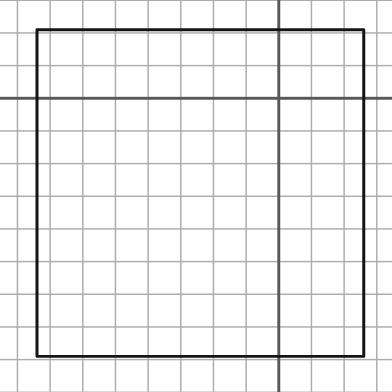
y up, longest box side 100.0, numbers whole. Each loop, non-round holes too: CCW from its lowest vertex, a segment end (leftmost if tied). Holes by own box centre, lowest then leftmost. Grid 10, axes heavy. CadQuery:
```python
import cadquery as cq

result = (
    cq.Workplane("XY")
    .moveTo(-74.0, -79.0)
    .lineTo(26.0, -79.0)
    .lineTo(26.0, 21.0)
    .lineTo(-74.0, 21.0)
    .close()
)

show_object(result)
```